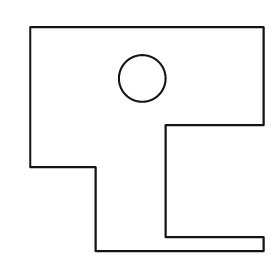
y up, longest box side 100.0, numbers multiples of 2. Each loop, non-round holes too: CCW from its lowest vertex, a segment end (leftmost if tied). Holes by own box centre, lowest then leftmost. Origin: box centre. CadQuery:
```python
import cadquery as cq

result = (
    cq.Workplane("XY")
    .moveTo(-22.0, -48.0)
    .lineTo(50.0, -48.0)
    .lineTo(50.0, -42.0)
    .lineTo(8.0, -42.0)
    .lineTo(8.0, 6.0)
    .lineTo(50.0, 6.0)
    .lineTo(50.0, 48.0)
    .lineTo(-50.0, 48.0)
    .lineTo(-50.0, -12.0)
    .lineTo(-22.0, -12.0)
    .close()
    .moveTo(-2.0, 26.0)
    .circle(10.0)
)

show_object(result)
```